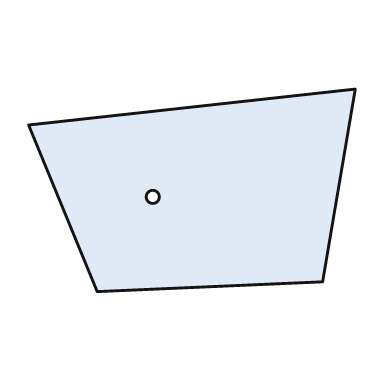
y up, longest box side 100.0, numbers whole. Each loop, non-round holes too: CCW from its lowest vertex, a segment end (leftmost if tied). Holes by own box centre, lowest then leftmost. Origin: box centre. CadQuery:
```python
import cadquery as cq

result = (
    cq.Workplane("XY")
    .moveTo(-29.0, -31.0)
    .lineTo(40.0, -28.0)
    .lineTo(50.0, 31.0)
    .lineTo(-50.0, 20.0)
    .close()
    .moveTo(-12.0, -2.0)
    .circle(2.0)
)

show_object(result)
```